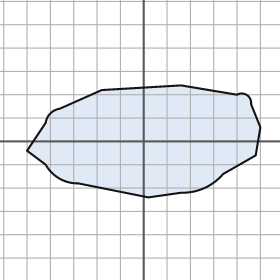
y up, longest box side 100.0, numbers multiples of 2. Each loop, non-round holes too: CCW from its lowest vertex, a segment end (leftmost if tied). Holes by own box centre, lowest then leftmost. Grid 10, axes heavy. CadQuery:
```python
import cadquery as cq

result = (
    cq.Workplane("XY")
    .moveTo(2.0, -24.0)
    .lineTo(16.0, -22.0)
    .threePointArc((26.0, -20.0), (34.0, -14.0))
    .lineTo(48.0, -6.0)
    .lineTo(50.0, 6.0)
    .lineTo(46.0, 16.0)
    .threePointArc((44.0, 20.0), (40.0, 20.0))
    .lineTo(16.0, 24.0)
    .lineTo(-18.0, 22.0)
    .lineTo(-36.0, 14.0)
    .threePointArc((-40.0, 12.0), (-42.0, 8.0))
    .lineTo(-50.0, -4.0)
    .lineTo(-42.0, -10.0)
    .threePointArc((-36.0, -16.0), (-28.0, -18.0))
    .close()
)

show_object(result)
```